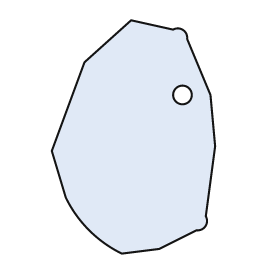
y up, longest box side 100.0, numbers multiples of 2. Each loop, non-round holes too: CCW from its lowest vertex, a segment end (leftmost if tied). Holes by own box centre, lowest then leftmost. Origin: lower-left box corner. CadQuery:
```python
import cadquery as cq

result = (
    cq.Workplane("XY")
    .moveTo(30.0, 0.0)
    .lineTo(46.0, 2.0)
    .lineTo(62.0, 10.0)
    .threePointArc((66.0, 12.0), (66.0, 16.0))
    .lineTo(70.0, 46.0)
    .lineTo(68.0, 68.0)
    .lineTo(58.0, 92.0)
    .threePointArc((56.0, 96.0), (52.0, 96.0))
    .lineTo(34.0, 100.0)
    .lineTo(14.0, 82.0)
    .lineTo(0.0, 44.0)
    .lineTo(6.0, 24.0)
    .threePointArc((16.0, 10.0), (30.0, 0.0))
    .close()
    .moveTo(56.0, 68.0)
    .circle(4.0)
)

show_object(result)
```